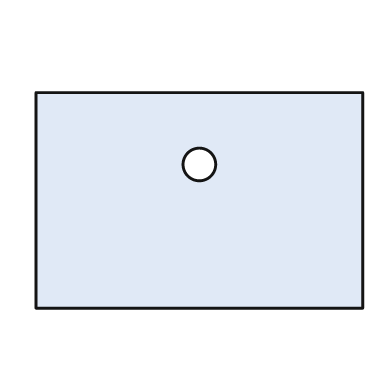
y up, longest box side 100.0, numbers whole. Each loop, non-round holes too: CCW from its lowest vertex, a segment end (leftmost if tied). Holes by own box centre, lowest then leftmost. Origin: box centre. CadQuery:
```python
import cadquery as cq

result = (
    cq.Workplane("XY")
    .moveTo(-50.0, -33.0)
    .lineTo(50.0, -33.0)
    .lineTo(50.0, 33.0)
    .lineTo(-50.0, 33.0)
    .close()
    .moveTo(0.0, 11.0)
    .circle(5.0)
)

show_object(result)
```